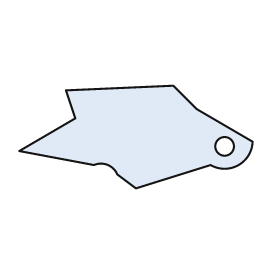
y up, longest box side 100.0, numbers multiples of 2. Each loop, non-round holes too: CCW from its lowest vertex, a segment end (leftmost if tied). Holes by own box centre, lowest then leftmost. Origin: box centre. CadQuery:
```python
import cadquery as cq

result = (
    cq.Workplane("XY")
    .moveTo(0.0, -22.0)
    .lineTo(32.0, -12.0)
    .threePointArc((44.0, -12.0), (50.0, -2.0))
    .lineTo(26.0, 12.0)
    .lineTo(16.0, 22.0)
    .lineTo(-30.0, 20.0)
    .lineTo(-26.0, 8.0)
    .lineTo(-50.0, -6.0)
    .lineTo(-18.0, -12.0)
    .threePointArc((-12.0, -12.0), (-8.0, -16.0))
    .close()
    .moveTo(38.0, -4.0)
    .circle(4.0)
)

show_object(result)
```